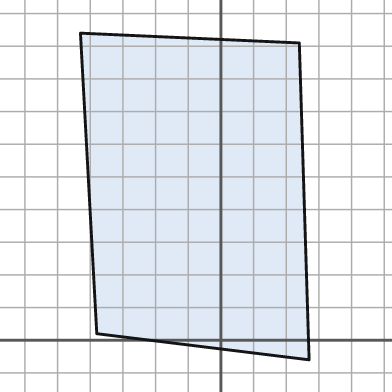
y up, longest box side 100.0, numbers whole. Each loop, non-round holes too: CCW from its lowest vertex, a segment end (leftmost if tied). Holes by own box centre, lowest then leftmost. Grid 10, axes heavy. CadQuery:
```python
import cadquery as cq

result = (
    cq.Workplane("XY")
    .moveTo(27.0, -6.0)
    .lineTo(24.0, 91.0)
    .lineTo(-43.0, 94.0)
    .lineTo(-38.0, 2.0)
    .close()
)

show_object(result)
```